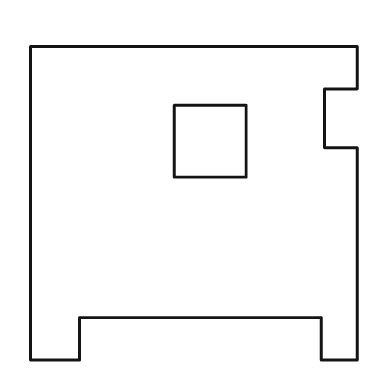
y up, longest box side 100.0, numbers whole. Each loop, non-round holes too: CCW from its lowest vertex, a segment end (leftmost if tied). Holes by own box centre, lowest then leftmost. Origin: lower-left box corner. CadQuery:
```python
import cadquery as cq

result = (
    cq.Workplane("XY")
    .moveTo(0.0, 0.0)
    .lineTo(15.0, 0.0)
    .lineTo(15.0, 13.0)
    .lineTo(89.0, 13.0)
    .lineTo(89.0, 0.0)
    .lineTo(100.0, 0.0)
    .lineTo(100.0, 65.0)
    .lineTo(90.0, 65.0)
    .lineTo(90.0, 83.0)
    .lineTo(100.0, 83.0)
    .lineTo(100.0, 96.0)
    .lineTo(0.0, 96.0)
    .close()
    .moveTo(44.0, 56.0)
    .lineTo(66.0, 56.0)
    .lineTo(66.0, 78.0)
    .lineTo(44.0, 78.0)
    .close()
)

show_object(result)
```